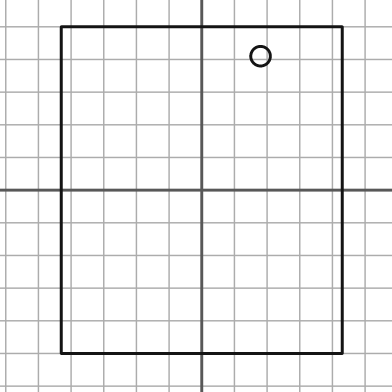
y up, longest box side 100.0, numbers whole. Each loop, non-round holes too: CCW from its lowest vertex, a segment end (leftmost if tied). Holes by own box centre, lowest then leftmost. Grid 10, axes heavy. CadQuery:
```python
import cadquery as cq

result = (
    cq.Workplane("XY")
    .moveTo(-43.0, -50.0)
    .lineTo(43.0, -50.0)
    .lineTo(43.0, 50.0)
    .lineTo(-43.0, 50.0)
    .close()
    .moveTo(18.0, 41.0)
    .circle(3.0)
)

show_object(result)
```